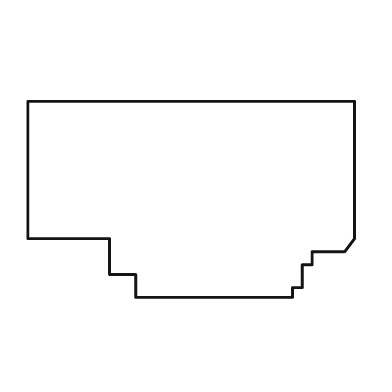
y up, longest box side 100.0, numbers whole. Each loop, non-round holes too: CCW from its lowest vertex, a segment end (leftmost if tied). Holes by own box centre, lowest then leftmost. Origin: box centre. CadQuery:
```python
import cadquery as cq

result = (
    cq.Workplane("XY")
    .moveTo(-17.0, -30.0)
    .lineTo(31.0, -30.0)
    .lineTo(31.0, -27.0)
    .lineTo(34.0, -27.0)
    .lineTo(34.0, -20.0)
    .lineTo(37.0, -20.0)
    .lineTo(37.0, -16.0)
    .lineTo(47.0, -16.0)
    .lineTo(50.0, -12.0)
    .lineTo(50.0, 30.0)
    .lineTo(-50.0, 30.0)
    .lineTo(-50.0, -12.0)
    .lineTo(-25.0, -12.0)
    .lineTo(-25.0, -23.0)
    .lineTo(-17.0, -23.0)
    .close()
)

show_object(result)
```